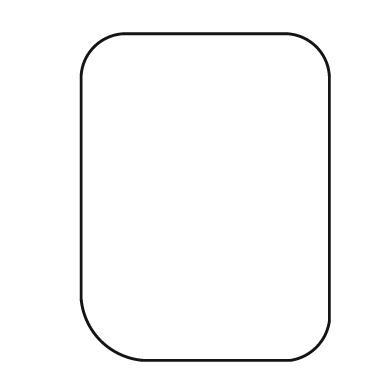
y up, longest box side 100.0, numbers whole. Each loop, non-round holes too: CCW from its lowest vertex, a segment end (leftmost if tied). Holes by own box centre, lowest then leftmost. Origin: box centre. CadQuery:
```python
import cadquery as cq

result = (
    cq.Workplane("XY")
    .moveTo(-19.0, -50.0)
    .lineTo(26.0, -50.0)
    .threePointArc((34.0, -46.0), (38.0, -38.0))
    .lineTo(38.0, 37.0)
    .threePointArc((34.0, 46.0), (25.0, 50.0))
    .lineTo(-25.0, 50.0)
    .threePointArc((-34.0, 46.0), (-38.0, 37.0))
    .lineTo(-38.0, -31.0)
    .threePointArc((-32.0, -44.0), (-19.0, -50.0))
    .close()
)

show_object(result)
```